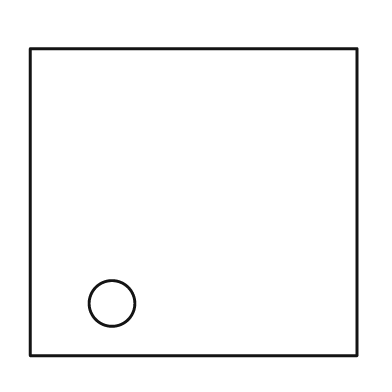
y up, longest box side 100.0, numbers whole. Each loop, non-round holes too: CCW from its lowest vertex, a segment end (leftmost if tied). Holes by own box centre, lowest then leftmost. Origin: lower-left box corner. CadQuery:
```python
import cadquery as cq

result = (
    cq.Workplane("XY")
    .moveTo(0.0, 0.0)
    .lineTo(100.0, 0.0)
    .lineTo(100.0, 94.0)
    .lineTo(0.0, 94.0)
    .close()
    .moveTo(25.0, 16.0)
    .circle(7.0)
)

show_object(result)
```